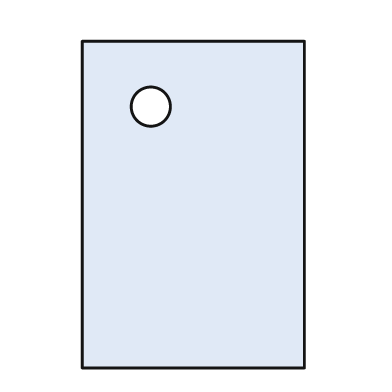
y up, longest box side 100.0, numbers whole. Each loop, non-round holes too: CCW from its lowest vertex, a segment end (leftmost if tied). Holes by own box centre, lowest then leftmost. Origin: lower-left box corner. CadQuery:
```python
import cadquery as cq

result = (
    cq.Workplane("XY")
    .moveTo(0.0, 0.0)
    .lineTo(68.0, 0.0)
    .lineTo(68.0, 100.0)
    .lineTo(0.0, 100.0)
    .close()
    .moveTo(21.0, 80.0)
    .circle(6.0)
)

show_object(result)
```